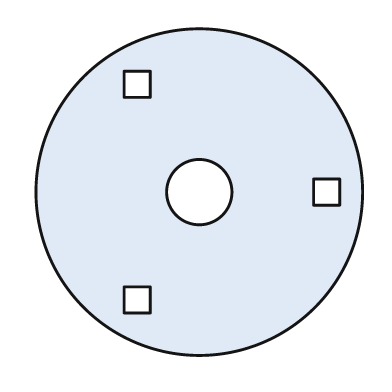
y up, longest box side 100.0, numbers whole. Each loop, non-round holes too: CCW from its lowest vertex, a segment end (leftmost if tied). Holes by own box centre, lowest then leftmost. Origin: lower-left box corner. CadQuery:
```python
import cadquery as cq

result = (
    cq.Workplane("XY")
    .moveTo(50.0, 50.0)
    .circle(50.0)
    .moveTo(27.0, 13.0)
    .lineTo(35.0, 13.0)
    .lineTo(35.0, 21.0)
    .lineTo(27.0, 21.0)
    .close()
    .moveTo(50.0, 50.0)
    .circle(10.0)
    .moveTo(85.0, 46.0)
    .lineTo(93.0, 46.0)
    .lineTo(93.0, 54.0)
    .lineTo(85.0, 54.0)
    .close()
    .moveTo(27.0, 79.0)
    .lineTo(35.0, 79.0)
    .lineTo(35.0, 87.0)
    .lineTo(27.0, 87.0)
    .close()
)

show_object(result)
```